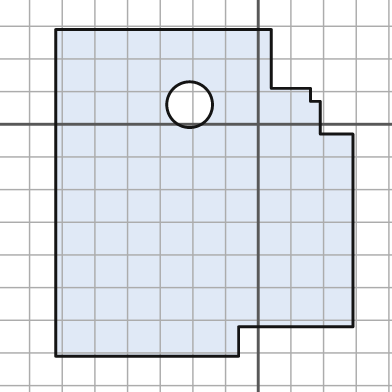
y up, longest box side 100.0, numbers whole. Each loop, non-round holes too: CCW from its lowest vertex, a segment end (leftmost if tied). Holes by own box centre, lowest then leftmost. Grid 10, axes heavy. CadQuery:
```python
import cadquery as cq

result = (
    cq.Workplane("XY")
    .moveTo(-62.0, -71.0)
    .lineTo(-6.0, -71.0)
    .lineTo(-6.0, -62.0)
    .lineTo(29.0, -62.0)
    .lineTo(29.0, -3.0)
    .lineTo(19.0, -3.0)
    .lineTo(19.0, 7.0)
    .lineTo(16.0, 7.0)
    .lineTo(16.0, 11.0)
    .lineTo(4.0, 11.0)
    .lineTo(4.0, 29.0)
    .lineTo(-62.0, 29.0)
    .close()
    .moveTo(-21.0, 6.0)
    .circle(7.0)
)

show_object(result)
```